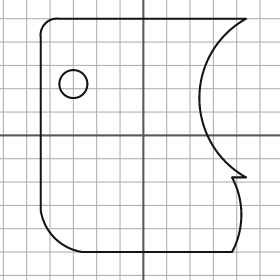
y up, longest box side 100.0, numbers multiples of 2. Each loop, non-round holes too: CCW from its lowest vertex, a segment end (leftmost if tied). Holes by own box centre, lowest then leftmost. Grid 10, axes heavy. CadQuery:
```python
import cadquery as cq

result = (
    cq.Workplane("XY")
    .moveTo(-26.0, -50.0)
    .lineTo(38.0, -50.0)
    .threePointArc((42.0, -34.0), (38.0, -18.0))
    .lineTo(44.0, -18.0)
    .threePointArc((24.0, 16.0), (44.0, 50.0))
    .lineTo(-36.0, 50.0)
    .threePointArc((-42.0, 48.0), (-44.0, 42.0))
    .lineTo(-44.0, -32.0)
    .threePointArc((-38.0, -44.0), (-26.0, -50.0))
    .close()
    .moveTo(-30.0, 22.0)
    .circle(6.0)
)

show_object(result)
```